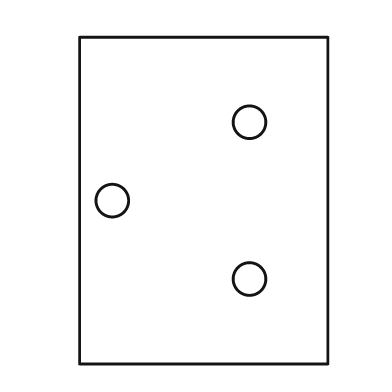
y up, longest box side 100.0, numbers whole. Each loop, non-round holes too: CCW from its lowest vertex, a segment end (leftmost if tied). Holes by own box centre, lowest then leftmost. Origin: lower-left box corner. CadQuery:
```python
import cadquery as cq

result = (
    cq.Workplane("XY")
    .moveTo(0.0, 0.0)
    .lineTo(76.0, 0.0)
    .lineTo(76.0, 100.0)
    .lineTo(0.0, 100.0)
    .close()
    .moveTo(52.0, 26.0)
    .circle(5.0)
    .moveTo(10.0, 50.0)
    .circle(5.0)
    .moveTo(52.0, 74.0)
    .circle(5.0)
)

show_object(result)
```